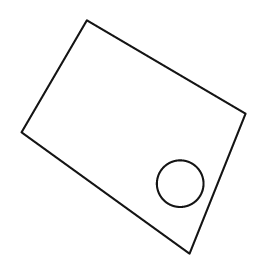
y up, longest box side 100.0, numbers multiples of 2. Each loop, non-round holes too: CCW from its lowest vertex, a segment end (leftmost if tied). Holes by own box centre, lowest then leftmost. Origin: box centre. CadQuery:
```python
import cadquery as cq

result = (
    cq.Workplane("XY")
    .moveTo(24.0, -50.0)
    .lineTo(48.0, 10.0)
    .lineTo(-20.0, 50.0)
    .lineTo(-48.0, 2.0)
    .close()
    .moveTo(20.0, -20.0)
    .circle(10.0)
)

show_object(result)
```